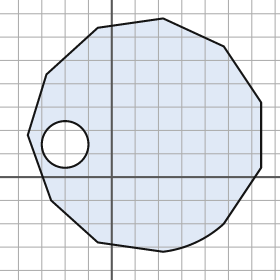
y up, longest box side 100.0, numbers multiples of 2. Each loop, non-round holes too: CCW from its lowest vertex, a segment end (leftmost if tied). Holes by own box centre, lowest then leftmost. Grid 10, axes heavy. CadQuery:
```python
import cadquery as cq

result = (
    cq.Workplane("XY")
    .moveTo(22.0, -32.0)
    .threePointArc((36.0, -28.0), (48.0, -20.0))
    .lineTo(64.0, 4.0)
    .lineTo(64.0, 32.0)
    .lineTo(48.0, 56.0)
    .lineTo(22.0, 68.0)
    .lineTo(-6.0, 64.0)
    .lineTo(-28.0, 44.0)
    .lineTo(-36.0, 18.0)
    .lineTo(-26.0, -10.0)
    .lineTo(-6.0, -28.0)
    .close()
    .moveTo(-20.0, 14.0)
    .circle(10.0)
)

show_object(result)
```